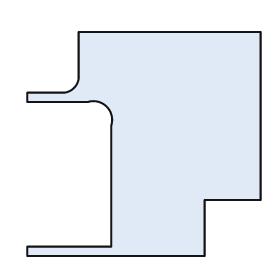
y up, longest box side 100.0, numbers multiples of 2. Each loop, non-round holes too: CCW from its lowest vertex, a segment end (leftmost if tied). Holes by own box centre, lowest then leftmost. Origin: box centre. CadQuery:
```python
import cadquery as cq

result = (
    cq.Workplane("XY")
    .moveTo(-50.0, -48.0)
    .lineTo(26.0, -48.0)
    .lineTo(26.0, -24.0)
    .lineTo(50.0, -24.0)
    .lineTo(50.0, 48.0)
    .lineTo(-28.0, 48.0)
    .lineTo(-28.0, 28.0)
    .threePointArc((-30.0, 24.0), (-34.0, 22.0))
    .lineTo(-50.0, 22.0)
    .lineTo(-50.0, 18.0)
    .lineTo(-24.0, 18.0)
    .threePointArc((-16.0, 16.0), (-14.0, 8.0))
    .lineTo(-14.0, -44.0)
    .lineTo(-50.0, -44.0)
    .close()
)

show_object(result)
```